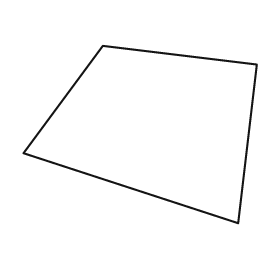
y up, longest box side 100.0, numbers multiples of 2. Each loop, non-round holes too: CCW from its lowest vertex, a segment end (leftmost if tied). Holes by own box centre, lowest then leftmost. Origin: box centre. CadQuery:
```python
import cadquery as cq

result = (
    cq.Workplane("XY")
    .moveTo(42.0, -38.0)
    .lineTo(50.0, 30.0)
    .lineTo(-16.0, 38.0)
    .lineTo(-50.0, -8.0)
    .close()
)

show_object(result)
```